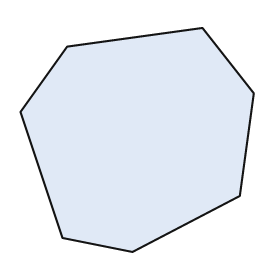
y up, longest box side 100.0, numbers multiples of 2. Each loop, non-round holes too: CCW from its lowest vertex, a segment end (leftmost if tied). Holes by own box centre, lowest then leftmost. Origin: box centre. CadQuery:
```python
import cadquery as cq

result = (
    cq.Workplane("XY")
    .moveTo(-2.0, -48.0)
    .lineTo(44.0, -24.0)
    .lineTo(50.0, 20.0)
    .lineTo(28.0, 48.0)
    .lineTo(-30.0, 40.0)
    .lineTo(-50.0, 12.0)
    .lineTo(-32.0, -42.0)
    .close()
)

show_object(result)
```